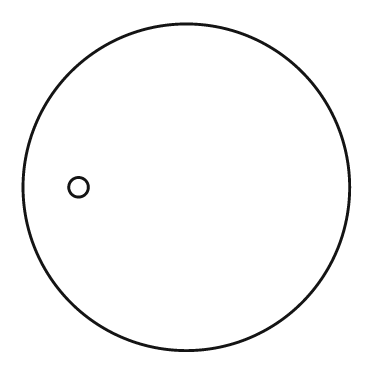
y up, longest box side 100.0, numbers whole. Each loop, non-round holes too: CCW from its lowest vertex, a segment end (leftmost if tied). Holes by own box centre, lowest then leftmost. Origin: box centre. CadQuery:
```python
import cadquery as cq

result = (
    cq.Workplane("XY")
    .moveTo(0.0, 0.0)
    .circle(50.0)
    .moveTo(-33.0, 0.0)
    .circle(3.0)
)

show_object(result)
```